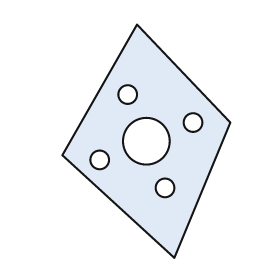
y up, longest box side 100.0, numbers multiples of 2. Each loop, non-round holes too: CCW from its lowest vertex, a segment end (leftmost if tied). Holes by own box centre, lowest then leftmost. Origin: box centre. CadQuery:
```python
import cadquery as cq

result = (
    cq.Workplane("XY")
    .moveTo(12.0, -50.0)
    .lineTo(36.0, 8.0)
    .lineTo(-4.0, 50.0)
    .lineTo(-36.0, -6.0)
    .close()
    .moveTo(8.0, -20.0)
    .circle(4.0)
    .moveTo(-20.0, -8.0)
    .circle(4.0)
    .moveTo(0.0, 0.0)
    .circle(10.0)
    .moveTo(20.0, 8.0)
    .circle(4.0)
    .moveTo(-8.0, 20.0)
    .circle(4.0)
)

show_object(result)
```